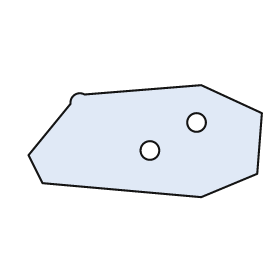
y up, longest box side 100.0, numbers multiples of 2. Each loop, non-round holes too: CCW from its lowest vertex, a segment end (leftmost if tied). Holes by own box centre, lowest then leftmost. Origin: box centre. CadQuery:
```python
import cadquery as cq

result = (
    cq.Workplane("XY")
    .moveTo(24.0, -24.0)
    .lineTo(48.0, -14.0)
    .lineTo(50.0, 12.0)
    .lineTo(24.0, 24.0)
    .lineTo(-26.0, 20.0)
    .threePointArc((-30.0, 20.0), (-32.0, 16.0))
    .lineTo(-50.0, -6.0)
    .lineTo(-44.0, -18.0)
    .close()
    .moveTo(2.0, -4.0)
    .circle(4.0)
    .moveTo(22.0, 8.0)
    .circle(4.0)
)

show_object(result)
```